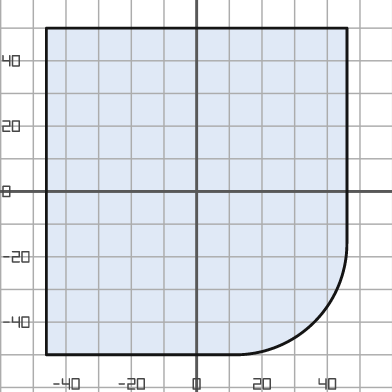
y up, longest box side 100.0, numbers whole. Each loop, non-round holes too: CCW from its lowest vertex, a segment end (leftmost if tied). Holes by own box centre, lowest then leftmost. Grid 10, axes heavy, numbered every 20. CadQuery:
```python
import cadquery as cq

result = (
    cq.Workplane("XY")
    .moveTo(-46.0, -50.0)
    .lineTo(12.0, -50.0)
    .threePointArc((36.0, -40.0), (46.0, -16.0))
    .lineTo(46.0, 50.0)
    .lineTo(-46.0, 50.0)
    .close()
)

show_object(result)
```